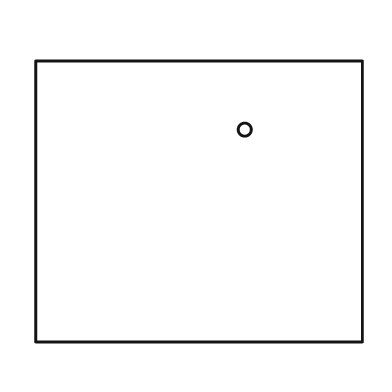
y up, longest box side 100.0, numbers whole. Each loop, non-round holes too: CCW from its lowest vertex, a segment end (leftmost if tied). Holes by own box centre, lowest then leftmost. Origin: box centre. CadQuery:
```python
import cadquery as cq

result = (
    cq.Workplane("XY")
    .moveTo(-50.0, -43.0)
    .lineTo(50.0, -43.0)
    .lineTo(50.0, 43.0)
    .lineTo(-50.0, 43.0)
    .close()
    .moveTo(14.0, 22.0)
    .circle(2.0)
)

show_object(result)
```